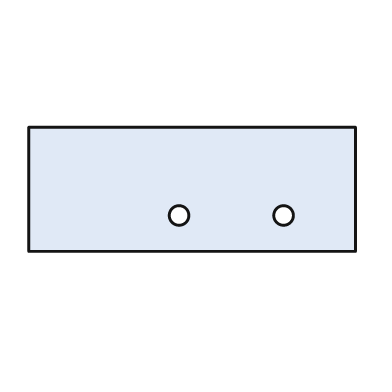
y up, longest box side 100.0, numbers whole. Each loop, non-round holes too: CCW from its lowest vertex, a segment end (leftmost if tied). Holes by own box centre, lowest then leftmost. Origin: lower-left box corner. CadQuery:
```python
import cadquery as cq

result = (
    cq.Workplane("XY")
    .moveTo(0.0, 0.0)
    .lineTo(100.0, 0.0)
    .lineTo(100.0, 38.0)
    .lineTo(0.0, 38.0)
    .close()
    .moveTo(46.0, 11.0)
    .circle(3.0)
    .moveTo(78.0, 11.0)
    .circle(3.0)
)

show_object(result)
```